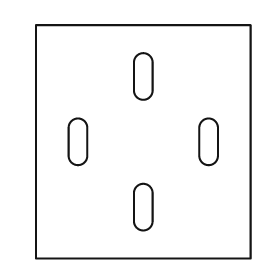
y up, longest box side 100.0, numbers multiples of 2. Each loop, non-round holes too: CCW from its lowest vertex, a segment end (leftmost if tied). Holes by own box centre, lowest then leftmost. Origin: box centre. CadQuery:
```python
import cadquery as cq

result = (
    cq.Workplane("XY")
    .moveTo(-46.0, -50.0)
    .lineTo(46.0, -50.0)
    .lineTo(46.0, 50.0)
    .lineTo(-46.0, 50.0)
    .close()
    .moveTo(-4.0, -34.0)
    .threePointArc((0.0, -38.0), (4.0, -34.0))
    .lineTo(4.0, -22.0)
    .threePointArc((0.0, -18.0), (-4.0, -22.0))
    .close()
    .moveTo(-32.0, -6.0)
    .threePointArc((-28.0, -10.0), (-24.0, -6.0))
    .lineTo(-24.0, 6.0)
    .threePointArc((-28.0, 10.0), (-32.0, 6.0))
    .close()
    .moveTo(24.0, -6.0)
    .threePointArc((28.0, -10.0), (32.0, -6.0))
    .lineTo(32.0, 6.0)
    .threePointArc((28.0, 10.0), (24.0, 6.0))
    .close()
    .moveTo(-4.0, 22.0)
    .threePointArc((0.0, 18.0), (4.0, 22.0))
    .lineTo(4.0, 34.0)
    .threePointArc((0.0, 38.0), (-4.0, 34.0))
    .close()
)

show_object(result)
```